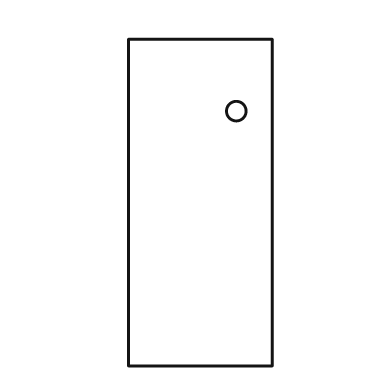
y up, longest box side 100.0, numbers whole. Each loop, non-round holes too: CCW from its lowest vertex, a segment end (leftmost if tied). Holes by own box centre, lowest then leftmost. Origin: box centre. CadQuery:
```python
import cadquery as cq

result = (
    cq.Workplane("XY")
    .moveTo(-22.0, -50.0)
    .lineTo(22.0, -50.0)
    .lineTo(22.0, 50.0)
    .lineTo(-22.0, 50.0)
    .close()
    .moveTo(11.0, 28.0)
    .circle(3.0)
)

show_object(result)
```